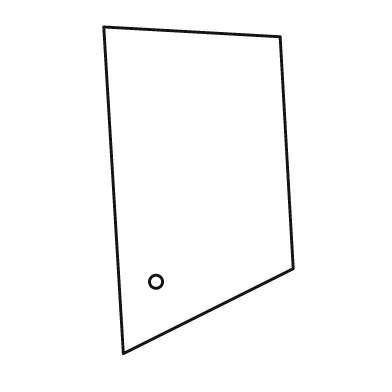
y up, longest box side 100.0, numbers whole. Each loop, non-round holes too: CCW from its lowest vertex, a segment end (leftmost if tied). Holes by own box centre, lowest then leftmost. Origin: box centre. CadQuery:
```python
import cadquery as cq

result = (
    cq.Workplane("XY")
    .moveTo(-23.0, -50.0)
    .lineTo(29.0, -24.0)
    .lineTo(25.0, 47.0)
    .lineTo(-29.0, 50.0)
    .close()
    .moveTo(-13.0, -28.0)
    .circle(2.0)
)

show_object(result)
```